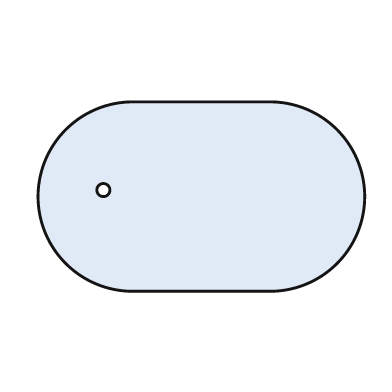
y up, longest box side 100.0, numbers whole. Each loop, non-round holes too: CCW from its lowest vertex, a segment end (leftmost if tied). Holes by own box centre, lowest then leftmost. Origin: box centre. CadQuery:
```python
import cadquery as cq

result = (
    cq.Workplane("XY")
    .moveTo(-21.0, -29.0)
    .lineTo(21.0, -29.0)
    .threePointArc((50.0, 0.0), (21.0, 29.0))
    .lineTo(-21.0, 29.0)
    .threePointArc((-50.0, 0.0), (-21.0, -29.0))
    .close()
    .moveTo(-30.0, 2.0)
    .circle(2.0)
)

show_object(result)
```